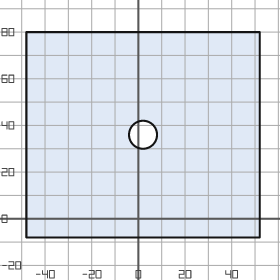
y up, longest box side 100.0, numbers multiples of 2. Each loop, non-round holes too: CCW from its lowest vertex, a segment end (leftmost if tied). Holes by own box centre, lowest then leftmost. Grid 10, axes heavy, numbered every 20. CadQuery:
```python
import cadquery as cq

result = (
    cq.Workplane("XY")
    .moveTo(-48.0, -8.0)
    .lineTo(52.0, -8.0)
    .lineTo(52.0, 80.0)
    .lineTo(-48.0, 80.0)
    .close()
    .moveTo(2.0, 36.0)
    .circle(6.0)
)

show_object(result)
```